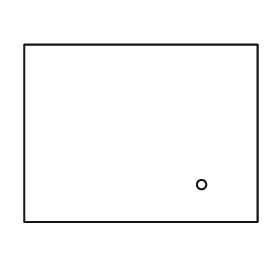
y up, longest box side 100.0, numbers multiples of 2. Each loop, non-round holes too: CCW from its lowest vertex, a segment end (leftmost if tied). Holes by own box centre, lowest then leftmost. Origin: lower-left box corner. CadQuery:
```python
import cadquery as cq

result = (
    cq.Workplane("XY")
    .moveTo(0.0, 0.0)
    .lineTo(100.0, 0.0)
    .lineTo(100.0, 76.0)
    .lineTo(0.0, 76.0)
    .close()
    .moveTo(76.0, 16.0)
    .circle(2.0)
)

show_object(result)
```